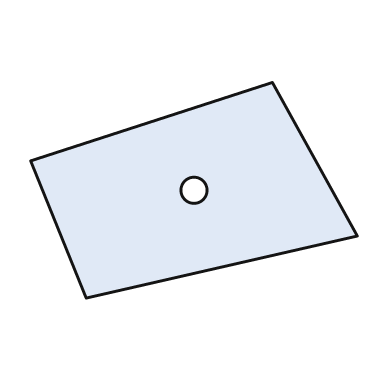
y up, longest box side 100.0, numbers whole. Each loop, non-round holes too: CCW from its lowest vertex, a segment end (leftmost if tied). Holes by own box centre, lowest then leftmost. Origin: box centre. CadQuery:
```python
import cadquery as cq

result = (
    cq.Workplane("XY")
    .moveTo(-33.0, -33.0)
    .lineTo(50.0, -14.0)
    .lineTo(24.0, 33.0)
    .lineTo(-50.0, 9.0)
    .close()
    .moveTo(0.0, 0.0)
    .circle(4.0)
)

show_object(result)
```